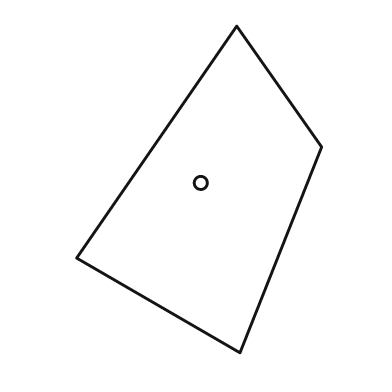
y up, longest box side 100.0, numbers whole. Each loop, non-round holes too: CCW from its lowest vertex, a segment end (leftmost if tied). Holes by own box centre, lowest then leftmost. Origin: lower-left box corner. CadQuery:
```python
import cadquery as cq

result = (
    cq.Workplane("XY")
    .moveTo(50.0, 0.0)
    .lineTo(75.0, 63.0)
    .lineTo(49.0, 100.0)
    .lineTo(0.0, 29.0)
    .close()
    .moveTo(38.0, 52.0)
    .circle(2.0)
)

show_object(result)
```